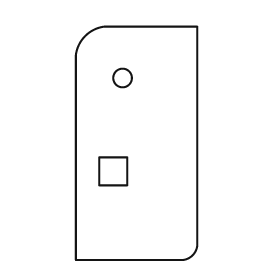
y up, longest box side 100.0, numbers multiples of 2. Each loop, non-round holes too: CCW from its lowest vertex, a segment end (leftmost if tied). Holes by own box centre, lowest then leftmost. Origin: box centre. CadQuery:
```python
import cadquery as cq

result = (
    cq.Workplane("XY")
    .moveTo(-26.0, -50.0)
    .lineTo(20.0, -50.0)
    .threePointArc((24.0, -48.0), (26.0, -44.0))
    .lineTo(26.0, 50.0)
    .lineTo(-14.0, 50.0)
    .threePointArc((-22.0, 46.0), (-26.0, 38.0))
    .close()
    .moveTo(-16.0, -18.0)
    .lineTo(-4.0, -18.0)
    .lineTo(-4.0, -6.0)
    .lineTo(-16.0, -6.0)
    .close()
    .moveTo(-6.0, 28.0)
    .circle(4.0)
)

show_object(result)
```